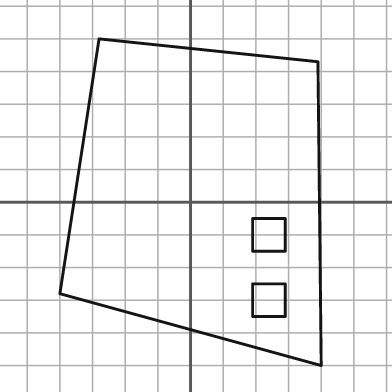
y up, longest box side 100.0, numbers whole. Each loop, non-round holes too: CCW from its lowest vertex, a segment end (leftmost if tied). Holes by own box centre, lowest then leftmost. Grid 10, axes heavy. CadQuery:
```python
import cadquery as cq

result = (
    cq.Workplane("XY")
    .moveTo(40.0, -50.0)
    .lineTo(39.0, 43.0)
    .lineTo(-28.0, 50.0)
    .lineTo(-40.0, -28.0)
    .close()
    .moveTo(19.0, -35.0)
    .lineTo(29.0, -35.0)
    .lineTo(29.0, -25.0)
    .lineTo(19.0, -25.0)
    .close()
    .moveTo(19.0, -15.0)
    .lineTo(29.0, -15.0)
    .lineTo(29.0, -5.0)
    .lineTo(19.0, -5.0)
    .close()
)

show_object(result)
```